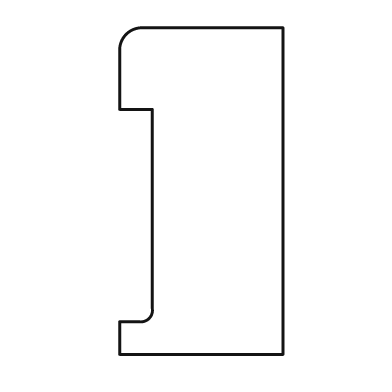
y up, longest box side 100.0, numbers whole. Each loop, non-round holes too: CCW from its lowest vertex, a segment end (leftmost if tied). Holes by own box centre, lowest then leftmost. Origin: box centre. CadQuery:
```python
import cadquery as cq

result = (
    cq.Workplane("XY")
    .moveTo(-25.0, -50.0)
    .lineTo(25.0, -50.0)
    .lineTo(25.0, 50.0)
    .lineTo(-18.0, 50.0)
    .threePointArc((-23.0, 48.0), (-25.0, 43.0))
    .lineTo(-25.0, 25.0)
    .lineTo(-15.0, 25.0)
    .lineTo(-15.0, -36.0)
    .threePointArc((-16.0, -39.0), (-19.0, -40.0))
    .lineTo(-25.0, -40.0)
    .close()
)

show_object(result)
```